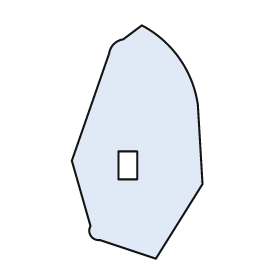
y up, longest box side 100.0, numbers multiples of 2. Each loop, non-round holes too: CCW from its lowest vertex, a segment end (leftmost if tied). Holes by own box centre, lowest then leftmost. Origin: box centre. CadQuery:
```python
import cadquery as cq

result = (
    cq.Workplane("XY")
    .moveTo(8.0, -50.0)
    .lineTo(28.0, -18.0)
    .lineTo(26.0, 16.0)
    .threePointArc((18.0, 36.0), (2.0, 50.0))
    .lineTo(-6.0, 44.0)
    .threePointArc((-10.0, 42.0), (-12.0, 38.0))
    .lineTo(-28.0, -8.0)
    .lineTo(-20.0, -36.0)
    .threePointArc((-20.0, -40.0), (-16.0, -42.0))
    .close()
    .moveTo(-8.0, -16.0)
    .lineTo(0.0, -16.0)
    .lineTo(0.0, -4.0)
    .lineTo(-8.0, -4.0)
    .close()
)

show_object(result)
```